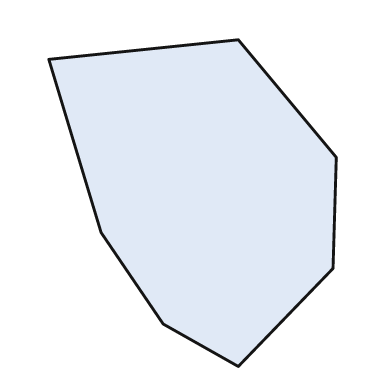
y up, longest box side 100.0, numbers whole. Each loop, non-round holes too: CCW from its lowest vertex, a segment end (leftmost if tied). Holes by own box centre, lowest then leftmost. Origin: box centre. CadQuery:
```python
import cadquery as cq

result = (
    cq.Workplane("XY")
    .moveTo(14.0, -50.0)
    .lineTo(43.0, -20.0)
    .lineTo(44.0, 14.0)
    .lineTo(14.0, 50.0)
    .lineTo(-44.0, 44.0)
    .lineTo(-28.0, -9.0)
    .lineTo(-9.0, -37.0)
    .close()
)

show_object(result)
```